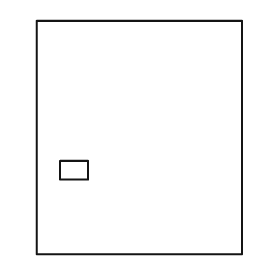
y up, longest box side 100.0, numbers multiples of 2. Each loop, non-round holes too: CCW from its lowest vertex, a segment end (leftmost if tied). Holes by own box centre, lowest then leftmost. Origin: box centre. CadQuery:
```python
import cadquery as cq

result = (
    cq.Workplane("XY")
    .moveTo(-44.0, -50.0)
    .lineTo(44.0, -50.0)
    .lineTo(44.0, 50.0)
    .lineTo(-44.0, 50.0)
    .close()
    .moveTo(-34.0, -18.0)
    .lineTo(-22.0, -18.0)
    .lineTo(-22.0, -10.0)
    .lineTo(-34.0, -10.0)
    .close()
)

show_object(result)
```